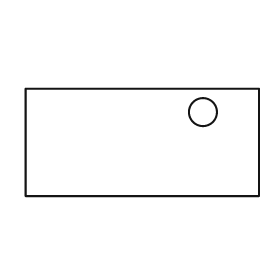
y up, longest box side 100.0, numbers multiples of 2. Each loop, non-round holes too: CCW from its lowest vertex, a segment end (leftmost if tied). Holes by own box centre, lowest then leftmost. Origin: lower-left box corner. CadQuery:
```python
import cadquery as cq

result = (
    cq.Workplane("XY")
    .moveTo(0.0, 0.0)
    .lineTo(100.0, 0.0)
    .lineTo(100.0, 46.0)
    .lineTo(0.0, 46.0)
    .close()
    .moveTo(76.0, 36.0)
    .circle(6.0)
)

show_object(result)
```